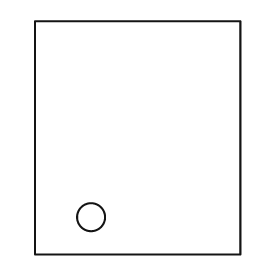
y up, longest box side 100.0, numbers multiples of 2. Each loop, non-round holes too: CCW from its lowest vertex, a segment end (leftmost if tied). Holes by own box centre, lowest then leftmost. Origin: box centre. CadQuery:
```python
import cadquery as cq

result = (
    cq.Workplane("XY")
    .moveTo(-44.0, -50.0)
    .lineTo(44.0, -50.0)
    .lineTo(44.0, 50.0)
    .lineTo(-44.0, 50.0)
    .close()
    .moveTo(-20.0, -34.0)
    .circle(6.0)
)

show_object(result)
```